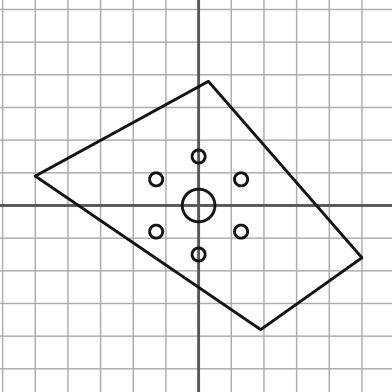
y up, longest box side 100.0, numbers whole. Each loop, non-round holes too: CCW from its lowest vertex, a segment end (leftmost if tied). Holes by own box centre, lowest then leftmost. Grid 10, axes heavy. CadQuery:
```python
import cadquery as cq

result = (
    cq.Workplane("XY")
    .moveTo(19.0, -38.0)
    .lineTo(50.0, -16.0)
    .lineTo(3.0, 38.0)
    .lineTo(-50.0, 9.0)
    .close()
    .moveTo(0.0, -15.0)
    .circle(2.0)
    .moveTo(-13.0, -8.0)
    .circle(2.0)
    .moveTo(13.0, -8.0)
    .circle(2.0)
    .moveTo(0.0, 0.0)
    .circle(5.0)
    .moveTo(-13.0, 8.0)
    .circle(2.0)
    .moveTo(13.0, 8.0)
    .circle(2.0)
    .moveTo(0.0, 15.0)
    .circle(2.0)
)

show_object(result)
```